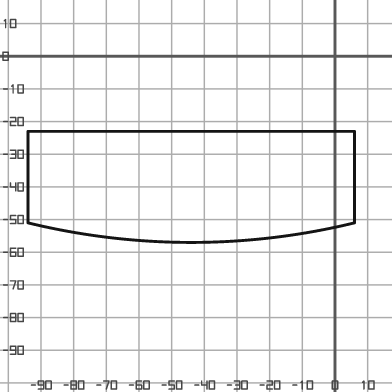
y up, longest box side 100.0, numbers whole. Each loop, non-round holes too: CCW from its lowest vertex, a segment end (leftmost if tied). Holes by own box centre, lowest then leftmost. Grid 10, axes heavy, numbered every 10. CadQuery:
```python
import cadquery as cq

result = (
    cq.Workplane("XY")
    .moveTo(-94.0, -51.0)
    .threePointArc((-44.0, -57.0), (6.0, -51.0))
    .lineTo(6.0, -23.0)
    .lineTo(-94.0, -23.0)
    .close()
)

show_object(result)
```